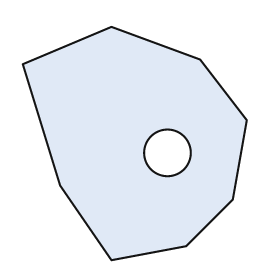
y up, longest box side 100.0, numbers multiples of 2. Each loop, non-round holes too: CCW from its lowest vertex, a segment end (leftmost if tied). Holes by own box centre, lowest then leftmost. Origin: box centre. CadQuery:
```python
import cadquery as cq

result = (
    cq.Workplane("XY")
    .moveTo(-10.0, -50.0)
    .lineTo(22.0, -44.0)
    .lineTo(42.0, -24.0)
    .lineTo(48.0, 10.0)
    .lineTo(28.0, 36.0)
    .lineTo(-10.0, 50.0)
    .lineTo(-48.0, 34.0)
    .lineTo(-32.0, -18.0)
    .close()
    .moveTo(14.0, -4.0)
    .circle(10.0)
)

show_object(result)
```